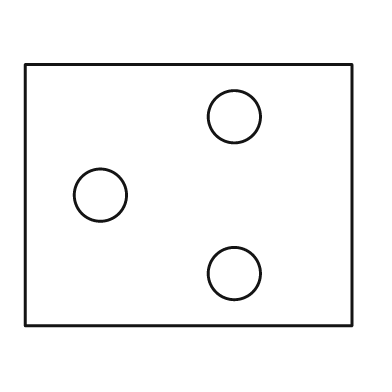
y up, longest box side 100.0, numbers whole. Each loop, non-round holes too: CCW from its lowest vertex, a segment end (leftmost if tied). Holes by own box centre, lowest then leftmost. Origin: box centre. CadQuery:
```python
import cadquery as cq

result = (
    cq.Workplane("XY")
    .moveTo(-50.0, -40.0)
    .lineTo(50.0, -40.0)
    .lineTo(50.0, 40.0)
    .lineTo(-50.0, 40.0)
    .close()
    .moveTo(14.0, -24.0)
    .circle(8.0)
    .moveTo(-27.0, 0.0)
    .circle(8.0)
    .moveTo(14.0, 24.0)
    .circle(8.0)
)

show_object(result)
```